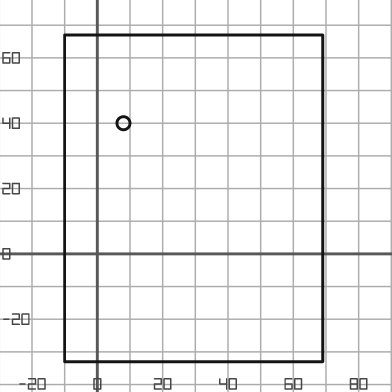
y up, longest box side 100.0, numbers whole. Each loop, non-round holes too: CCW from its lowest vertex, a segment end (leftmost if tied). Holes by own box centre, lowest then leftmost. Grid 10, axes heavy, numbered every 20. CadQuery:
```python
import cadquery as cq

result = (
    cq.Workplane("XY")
    .moveTo(-10.0, -33.0)
    .lineTo(69.0, -33.0)
    .lineTo(69.0, 67.0)
    .lineTo(-10.0, 67.0)
    .close()
    .moveTo(8.0, 40.0)
    .circle(2.0)
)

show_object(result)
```